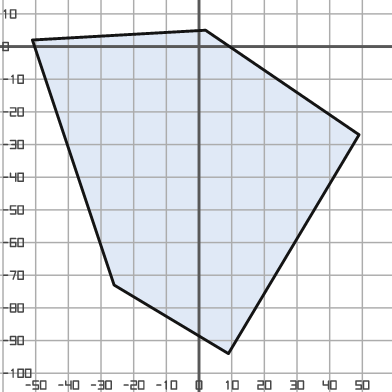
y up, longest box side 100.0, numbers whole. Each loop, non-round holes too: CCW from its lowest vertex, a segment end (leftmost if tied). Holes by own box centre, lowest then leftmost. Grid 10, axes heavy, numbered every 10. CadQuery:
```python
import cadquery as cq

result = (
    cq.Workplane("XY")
    .moveTo(9.0, -94.0)
    .lineTo(49.0, -27.0)
    .lineTo(2.0, 5.0)
    .lineTo(-51.0, 2.0)
    .lineTo(-26.0, -73.0)
    .close()
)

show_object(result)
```